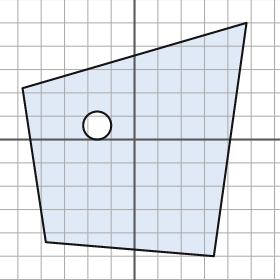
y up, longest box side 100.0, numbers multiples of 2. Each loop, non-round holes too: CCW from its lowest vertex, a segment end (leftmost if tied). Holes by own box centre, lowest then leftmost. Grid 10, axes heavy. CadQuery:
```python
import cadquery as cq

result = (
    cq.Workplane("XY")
    .moveTo(34.0, -50.0)
    .lineTo(48.0, 50.0)
    .lineTo(-48.0, 22.0)
    .lineTo(-38.0, -44.0)
    .close()
    .moveTo(-16.0, 6.0)
    .circle(6.0)
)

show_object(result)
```